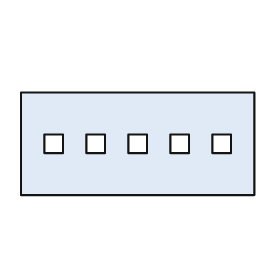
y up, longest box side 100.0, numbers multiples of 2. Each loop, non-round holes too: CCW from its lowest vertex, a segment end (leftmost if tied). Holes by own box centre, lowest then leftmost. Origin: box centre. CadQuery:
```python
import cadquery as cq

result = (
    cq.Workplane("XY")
    .moveTo(-50.0, -22.0)
    .lineTo(50.0, -22.0)
    .lineTo(50.0, 22.0)
    .lineTo(-50.0, 22.0)
    .close()
    .moveTo(-40.0, -4.0)
    .lineTo(-32.0, -4.0)
    .lineTo(-32.0, 4.0)
    .lineTo(-40.0, 4.0)
    .close()
    .moveTo(-22.0, -4.0)
    .lineTo(-14.0, -4.0)
    .lineTo(-14.0, 4.0)
    .lineTo(-22.0, 4.0)
    .close()
    .moveTo(-4.0, -4.0)
    .lineTo(4.0, -4.0)
    .lineTo(4.0, 4.0)
    .lineTo(-4.0, 4.0)
    .close()
    .moveTo(14.0, -4.0)
    .lineTo(22.0, -4.0)
    .lineTo(22.0, 4.0)
    .lineTo(14.0, 4.0)
    .close()
    .moveTo(32.0, -4.0)
    .lineTo(40.0, -4.0)
    .lineTo(40.0, 4.0)
    .lineTo(32.0, 4.0)
    .close()
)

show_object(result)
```